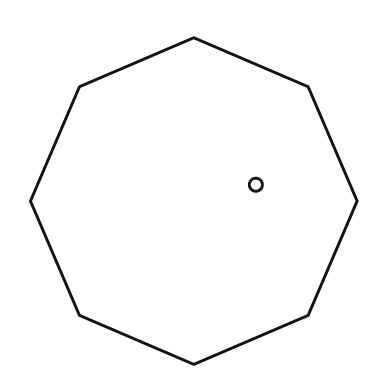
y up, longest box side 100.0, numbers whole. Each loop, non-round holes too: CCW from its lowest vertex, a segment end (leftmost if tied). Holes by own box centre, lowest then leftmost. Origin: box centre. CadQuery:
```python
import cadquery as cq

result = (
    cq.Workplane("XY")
    .moveTo(0.0, -50.0)
    .lineTo(35.0, -35.0)
    .lineTo(50.0, 0.0)
    .lineTo(35.0, 35.0)
    .lineTo(0.0, 50.0)
    .lineTo(-35.0, 35.0)
    .lineTo(-50.0, 0.0)
    .lineTo(-35.0, -35.0)
    .close()
    .moveTo(19.0, 5.0)
    .circle(2.0)
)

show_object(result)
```